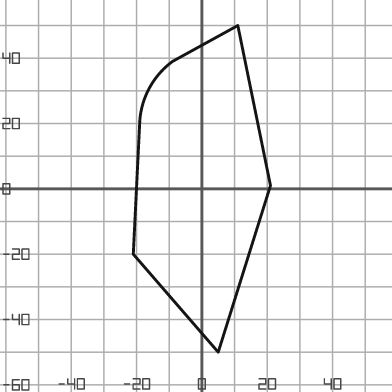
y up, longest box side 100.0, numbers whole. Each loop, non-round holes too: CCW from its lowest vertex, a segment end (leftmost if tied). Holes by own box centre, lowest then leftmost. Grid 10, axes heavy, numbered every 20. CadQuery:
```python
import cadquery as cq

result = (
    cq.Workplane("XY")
    .moveTo(5.0, -50.0)
    .lineTo(21.0, 1.0)
    .lineTo(11.0, 50.0)
    .lineTo(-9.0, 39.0)
    .threePointArc((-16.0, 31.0), (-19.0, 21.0))
    .lineTo(-21.0, -20.0)
    .close()
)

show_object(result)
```